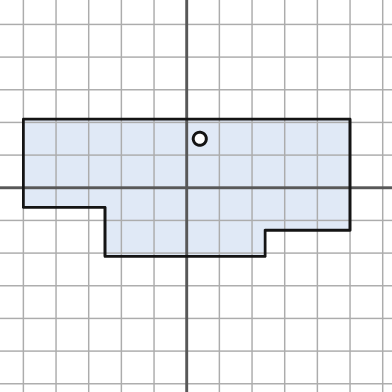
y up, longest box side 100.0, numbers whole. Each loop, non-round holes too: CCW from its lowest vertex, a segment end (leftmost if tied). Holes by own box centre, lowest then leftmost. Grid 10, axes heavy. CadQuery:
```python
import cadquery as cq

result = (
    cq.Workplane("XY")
    .moveTo(-25.0, -21.0)
    .lineTo(24.0, -21.0)
    .lineTo(24.0, -13.0)
    .lineTo(50.0, -13.0)
    .lineTo(50.0, 21.0)
    .lineTo(-50.0, 21.0)
    .lineTo(-50.0, -6.0)
    .lineTo(-25.0, -6.0)
    .close()
    .moveTo(4.0, 15.0)
    .circle(2.0)
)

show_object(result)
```